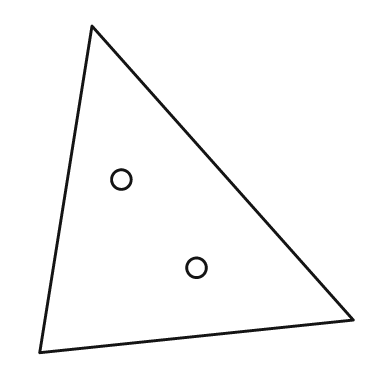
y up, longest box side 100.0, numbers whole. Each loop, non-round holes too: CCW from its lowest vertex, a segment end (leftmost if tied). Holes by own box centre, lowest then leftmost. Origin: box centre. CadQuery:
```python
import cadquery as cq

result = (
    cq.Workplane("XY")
    .moveTo(-48.0, -50.0)
    .lineTo(48.0, -40.0)
    .lineTo(-32.0, 50.0)
    .close()
    .moveTo(0.0, -24.0)
    .circle(3.0)
    .moveTo(-23.0, 3.0)
    .circle(3.0)
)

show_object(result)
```